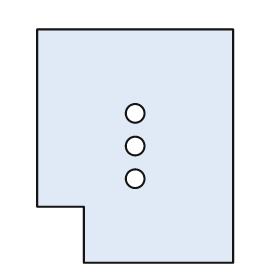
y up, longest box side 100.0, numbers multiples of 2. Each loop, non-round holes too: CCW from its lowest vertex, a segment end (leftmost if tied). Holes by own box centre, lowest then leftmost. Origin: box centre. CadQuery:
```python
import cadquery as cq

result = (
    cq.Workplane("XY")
    .moveTo(-22.0, -50.0)
    .lineTo(42.0, -50.0)
    .lineTo(42.0, 50.0)
    .lineTo(-42.0, 50.0)
    .lineTo(-42.0, -26.0)
    .lineTo(-22.0, -26.0)
    .close()
    .moveTo(0.0, -14.0)
    .circle(4.0)
    .moveTo(0.0, 0.0)
    .circle(4.0)
    .moveTo(0.0, 14.0)
    .circle(4.0)
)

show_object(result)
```